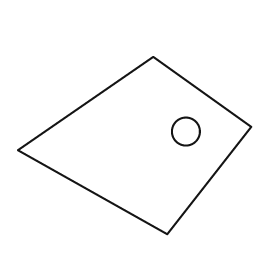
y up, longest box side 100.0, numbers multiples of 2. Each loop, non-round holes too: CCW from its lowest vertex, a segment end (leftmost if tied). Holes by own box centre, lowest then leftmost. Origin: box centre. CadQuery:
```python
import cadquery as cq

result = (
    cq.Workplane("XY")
    .moveTo(14.0, -38.0)
    .lineTo(50.0, 8.0)
    .lineTo(8.0, 38.0)
    .lineTo(-50.0, -2.0)
    .close()
    .moveTo(22.0, 6.0)
    .circle(6.0)
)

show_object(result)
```